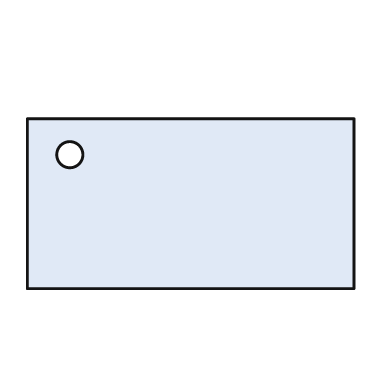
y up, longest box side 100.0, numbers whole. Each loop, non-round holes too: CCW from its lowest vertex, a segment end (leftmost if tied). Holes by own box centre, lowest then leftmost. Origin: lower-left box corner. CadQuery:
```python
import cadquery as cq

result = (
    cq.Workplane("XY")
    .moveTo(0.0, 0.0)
    .lineTo(100.0, 0.0)
    .lineTo(100.0, 52.0)
    .lineTo(0.0, 52.0)
    .close()
    .moveTo(13.0, 41.0)
    .circle(4.0)
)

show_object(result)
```